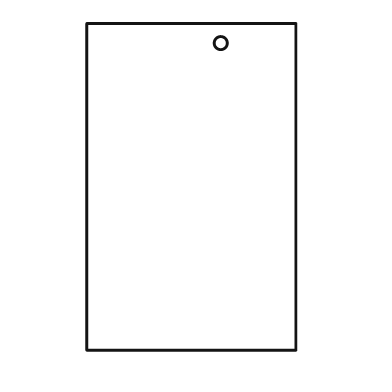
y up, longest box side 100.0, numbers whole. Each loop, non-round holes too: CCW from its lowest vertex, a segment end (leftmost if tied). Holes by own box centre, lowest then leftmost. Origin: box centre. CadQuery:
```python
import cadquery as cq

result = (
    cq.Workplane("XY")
    .moveTo(-32.0, -50.0)
    .lineTo(32.0, -50.0)
    .lineTo(32.0, 50.0)
    .lineTo(-32.0, 50.0)
    .close()
    .moveTo(9.0, 44.0)
    .circle(2.0)
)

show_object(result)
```